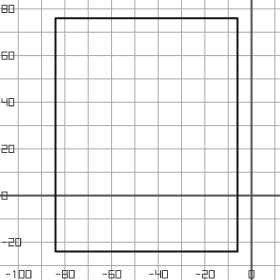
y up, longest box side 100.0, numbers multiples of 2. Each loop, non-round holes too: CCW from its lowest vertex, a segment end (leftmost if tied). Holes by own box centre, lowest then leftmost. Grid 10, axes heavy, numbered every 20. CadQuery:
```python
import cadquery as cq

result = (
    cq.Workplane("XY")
    .moveTo(-84.0, -24.0)
    .lineTo(-6.0, -24.0)
    .lineTo(-6.0, 76.0)
    .lineTo(-84.0, 76.0)
    .close()
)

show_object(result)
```